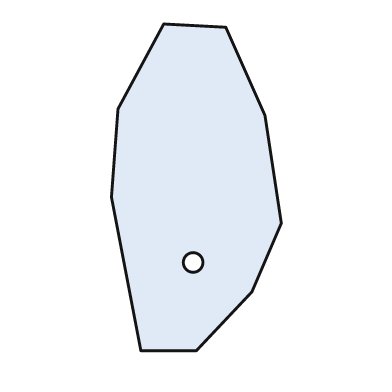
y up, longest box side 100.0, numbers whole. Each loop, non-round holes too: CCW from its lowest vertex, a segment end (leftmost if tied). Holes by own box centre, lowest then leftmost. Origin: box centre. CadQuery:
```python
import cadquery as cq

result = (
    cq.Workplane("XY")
    .moveTo(-17.0, -50.0)
    .lineTo(0.0, -50.0)
    .lineTo(17.0, -32.0)
    .lineTo(26.0, -11.0)
    .lineTo(21.0, 22.0)
    .lineTo(9.0, 49.0)
    .lineTo(-10.0, 50.0)
    .lineTo(-24.0, 24.0)
    .lineTo(-26.0, -3.0)
    .close()
    .moveTo(-1.0, -23.0)
    .circle(3.0)
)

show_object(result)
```